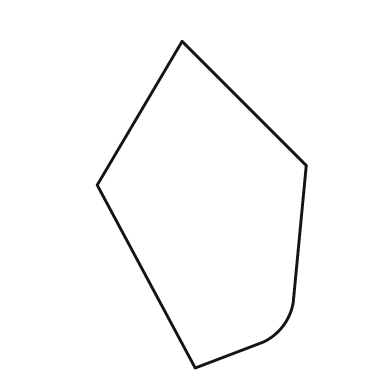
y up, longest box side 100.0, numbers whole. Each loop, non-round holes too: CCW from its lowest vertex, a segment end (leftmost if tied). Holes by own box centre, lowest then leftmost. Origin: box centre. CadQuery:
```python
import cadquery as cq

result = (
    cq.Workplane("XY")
    .moveTo(-2.0, -50.0)
    .lineTo(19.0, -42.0)
    .threePointArc((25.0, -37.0), (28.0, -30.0))
    .lineTo(32.0, 12.0)
    .lineTo(-6.0, 50.0)
    .lineTo(-32.0, 6.0)
    .close()
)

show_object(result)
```